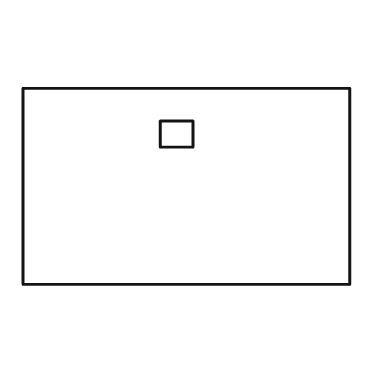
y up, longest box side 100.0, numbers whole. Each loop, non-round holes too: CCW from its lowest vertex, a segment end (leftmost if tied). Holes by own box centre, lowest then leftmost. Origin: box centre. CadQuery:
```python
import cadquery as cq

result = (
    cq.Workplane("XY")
    .moveTo(-50.0, -30.0)
    .lineTo(50.0, -30.0)
    .lineTo(50.0, 30.0)
    .lineTo(-50.0, 30.0)
    .close()
    .moveTo(-8.0, 12.0)
    .lineTo(2.0, 12.0)
    .lineTo(2.0, 20.0)
    .lineTo(-8.0, 20.0)
    .close()
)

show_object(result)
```